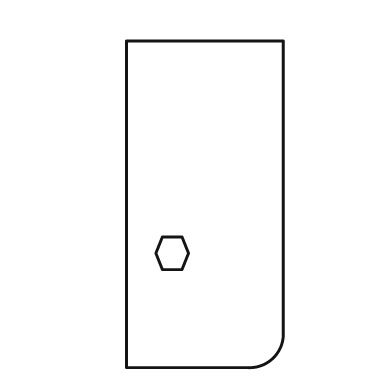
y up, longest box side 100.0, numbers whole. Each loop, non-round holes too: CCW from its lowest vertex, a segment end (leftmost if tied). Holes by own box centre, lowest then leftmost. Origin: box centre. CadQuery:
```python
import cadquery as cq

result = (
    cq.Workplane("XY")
    .moveTo(-24.0, -50.0)
    .lineTo(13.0, -50.0)
    .threePointArc((21.0, -47.0), (24.0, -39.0))
    .lineTo(24.0, 50.0)
    .lineTo(-24.0, 50.0)
    .close()
    .moveTo(-13.0, -20.0)
    .lineTo(-7.0, -20.0)
    .lineTo(-5.0, -15.0)
    .lineTo(-7.0, -10.0)
    .lineTo(-13.0, -10.0)
    .lineTo(-15.0, -15.0)
    .close()
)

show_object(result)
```